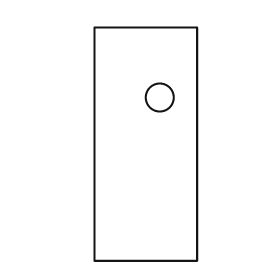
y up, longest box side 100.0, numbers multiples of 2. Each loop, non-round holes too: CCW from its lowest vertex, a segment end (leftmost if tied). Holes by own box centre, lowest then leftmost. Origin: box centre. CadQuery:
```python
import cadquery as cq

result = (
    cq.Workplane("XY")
    .moveTo(-22.0, -50.0)
    .lineTo(22.0, -50.0)
    .lineTo(22.0, 50.0)
    .lineTo(-22.0, 50.0)
    .close()
    .moveTo(6.0, 20.0)
    .circle(6.0)
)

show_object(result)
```